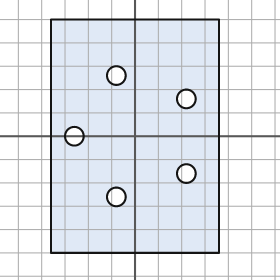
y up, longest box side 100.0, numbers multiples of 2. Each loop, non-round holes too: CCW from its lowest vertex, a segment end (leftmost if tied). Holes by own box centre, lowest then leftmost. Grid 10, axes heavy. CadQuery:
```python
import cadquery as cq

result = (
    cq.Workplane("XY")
    .moveTo(-36.0, -50.0)
    .lineTo(36.0, -50.0)
    .lineTo(36.0, 50.0)
    .lineTo(-36.0, 50.0)
    .close()
    .moveTo(-8.0, -26.0)
    .circle(4.0)
    .moveTo(22.0, -16.0)
    .circle(4.0)
    .moveTo(-26.0, 0.0)
    .circle(4.0)
    .moveTo(22.0, 16.0)
    .circle(4.0)
    .moveTo(-8.0, 26.0)
    .circle(4.0)
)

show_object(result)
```